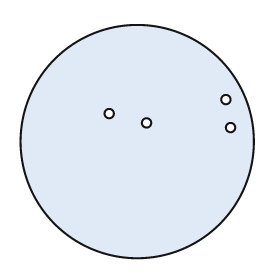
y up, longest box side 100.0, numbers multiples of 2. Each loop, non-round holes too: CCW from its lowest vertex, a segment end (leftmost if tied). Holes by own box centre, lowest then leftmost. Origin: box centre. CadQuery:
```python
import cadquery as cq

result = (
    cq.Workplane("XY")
    .moveTo(0.0, 0.0)
    .circle(50.0)
    .moveTo(40.0, 6.0)
    .circle(2.0)
    .moveTo(4.0, 8.0)
    .circle(2.0)
    .moveTo(-12.0, 12.0)
    .circle(2.0)
    .moveTo(38.0, 18.0)
    .circle(2.0)
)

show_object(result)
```